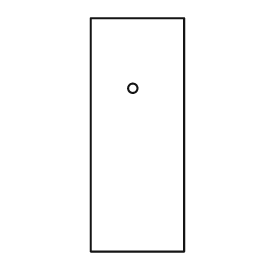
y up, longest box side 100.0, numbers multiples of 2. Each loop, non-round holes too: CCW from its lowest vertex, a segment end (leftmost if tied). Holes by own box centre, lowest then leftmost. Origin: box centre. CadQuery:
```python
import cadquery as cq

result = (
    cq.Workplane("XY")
    .moveTo(-20.0, -50.0)
    .lineTo(20.0, -50.0)
    .lineTo(20.0, 50.0)
    .lineTo(-20.0, 50.0)
    .close()
    .moveTo(-2.0, 20.0)
    .circle(2.0)
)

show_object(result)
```